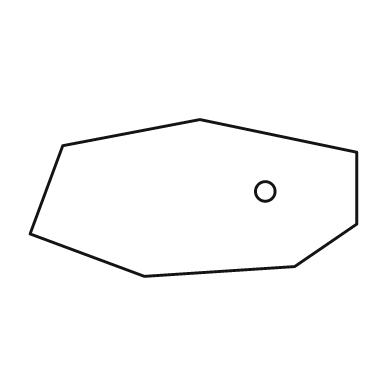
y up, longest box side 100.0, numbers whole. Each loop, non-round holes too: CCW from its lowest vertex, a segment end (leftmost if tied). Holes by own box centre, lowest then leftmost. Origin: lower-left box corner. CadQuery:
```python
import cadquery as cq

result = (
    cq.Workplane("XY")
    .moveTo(35.0, 0.0)
    .lineTo(81.0, 3.0)
    .lineTo(100.0, 16.0)
    .lineTo(100.0, 38.0)
    .lineTo(52.0, 48.0)
    .lineTo(10.0, 40.0)
    .lineTo(0.0, 13.0)
    .close()
    .moveTo(72.0, 26.0)
    .circle(3.0)
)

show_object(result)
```